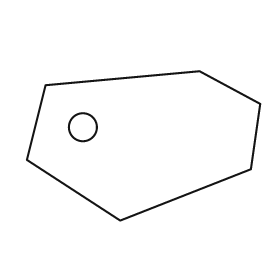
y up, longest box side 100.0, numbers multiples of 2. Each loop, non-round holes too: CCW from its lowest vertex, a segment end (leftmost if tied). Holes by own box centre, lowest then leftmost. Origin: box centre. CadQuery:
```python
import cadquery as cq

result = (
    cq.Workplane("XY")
    .moveTo(-10.0, -32.0)
    .lineTo(46.0, -10.0)
    .lineTo(50.0, 18.0)
    .lineTo(24.0, 32.0)
    .lineTo(-42.0, 26.0)
    .lineTo(-50.0, -6.0)
    .close()
    .moveTo(-26.0, 8.0)
    .circle(6.0)
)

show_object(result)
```